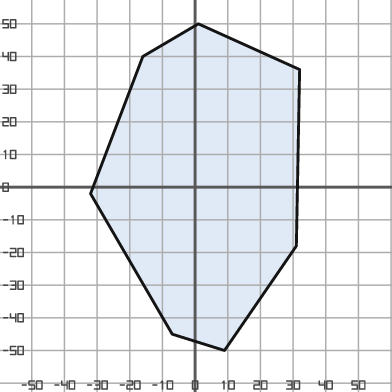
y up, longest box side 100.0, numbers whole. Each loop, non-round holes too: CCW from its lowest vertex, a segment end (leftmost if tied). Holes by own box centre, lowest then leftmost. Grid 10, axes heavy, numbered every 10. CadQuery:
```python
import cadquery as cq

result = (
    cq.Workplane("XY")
    .moveTo(9.0, -50.0)
    .lineTo(31.0, -18.0)
    .lineTo(32.0, 36.0)
    .lineTo(1.0, 50.0)
    .lineTo(-16.0, 40.0)
    .lineTo(-32.0, -2.0)
    .lineTo(-7.0, -45.0)
    .close()
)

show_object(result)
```